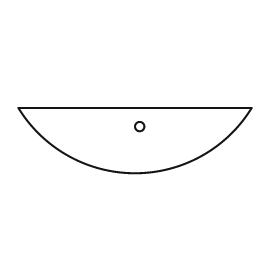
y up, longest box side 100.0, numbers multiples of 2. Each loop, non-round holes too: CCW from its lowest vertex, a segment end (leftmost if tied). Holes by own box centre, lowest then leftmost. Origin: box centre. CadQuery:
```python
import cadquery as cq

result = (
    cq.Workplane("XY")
    .moveTo(-50.0, 14.0)
    .threePointArc((0.0, -14.0), (50.0, 14.0))
    .close()
    .moveTo(2.0, 6.0)
    .circle(2.0)
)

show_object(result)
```